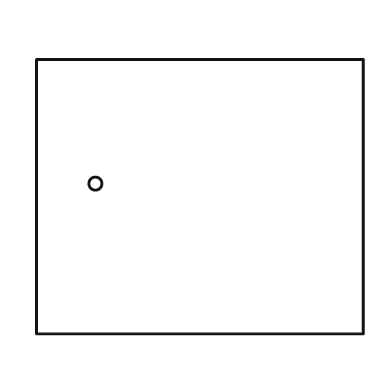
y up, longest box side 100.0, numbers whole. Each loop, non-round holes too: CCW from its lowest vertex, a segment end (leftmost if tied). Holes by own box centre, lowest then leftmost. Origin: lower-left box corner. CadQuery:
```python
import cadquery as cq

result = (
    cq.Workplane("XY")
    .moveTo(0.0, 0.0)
    .lineTo(100.0, 0.0)
    .lineTo(100.0, 84.0)
    .lineTo(0.0, 84.0)
    .close()
    .moveTo(18.0, 46.0)
    .circle(2.0)
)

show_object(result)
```